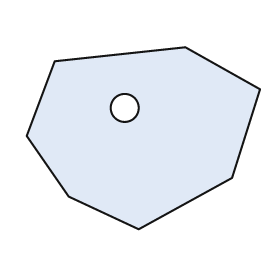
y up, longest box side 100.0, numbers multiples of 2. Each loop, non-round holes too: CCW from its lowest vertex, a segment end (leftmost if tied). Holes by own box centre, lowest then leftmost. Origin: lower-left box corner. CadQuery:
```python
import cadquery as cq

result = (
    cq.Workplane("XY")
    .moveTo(48.0, 0.0)
    .lineTo(88.0, 22.0)
    .lineTo(100.0, 60.0)
    .lineTo(68.0, 78.0)
    .lineTo(12.0, 72.0)
    .lineTo(0.0, 40.0)
    .lineTo(18.0, 14.0)
    .close()
    .moveTo(42.0, 52.0)
    .circle(6.0)
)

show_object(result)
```